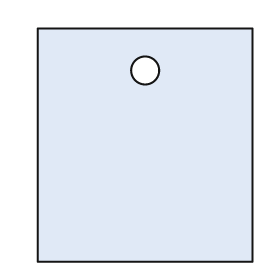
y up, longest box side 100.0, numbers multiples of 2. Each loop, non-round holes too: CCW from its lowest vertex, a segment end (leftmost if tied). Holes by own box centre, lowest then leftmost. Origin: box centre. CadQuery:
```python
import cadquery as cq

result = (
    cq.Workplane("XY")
    .moveTo(-46.0, -50.0)
    .lineTo(46.0, -50.0)
    .lineTo(46.0, 50.0)
    .lineTo(-46.0, 50.0)
    .close()
    .moveTo(0.0, 32.0)
    .circle(6.0)
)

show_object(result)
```